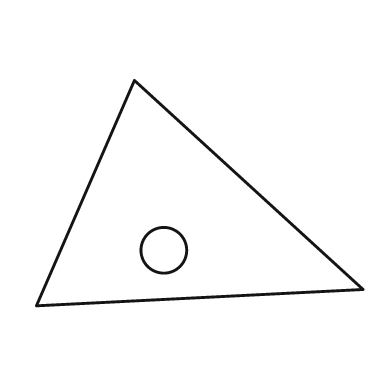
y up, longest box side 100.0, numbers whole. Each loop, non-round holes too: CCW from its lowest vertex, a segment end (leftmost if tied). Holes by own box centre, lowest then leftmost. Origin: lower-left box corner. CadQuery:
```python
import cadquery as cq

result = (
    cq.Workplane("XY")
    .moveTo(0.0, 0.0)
    .lineTo(100.0, 5.0)
    .lineTo(30.0, 69.0)
    .close()
    .moveTo(39.0, 17.0)
    .circle(7.0)
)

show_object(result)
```